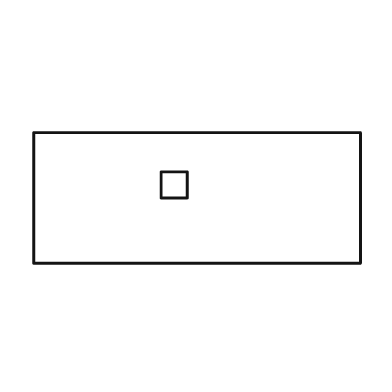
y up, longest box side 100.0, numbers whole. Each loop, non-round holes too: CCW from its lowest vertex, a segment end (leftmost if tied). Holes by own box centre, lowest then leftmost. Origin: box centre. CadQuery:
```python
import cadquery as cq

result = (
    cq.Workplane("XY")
    .moveTo(-50.0, -20.0)
    .lineTo(50.0, -20.0)
    .lineTo(50.0, 20.0)
    .lineTo(-50.0, 20.0)
    .close()
    .moveTo(-11.0, 0.0)
    .lineTo(-3.0, 0.0)
    .lineTo(-3.0, 8.0)
    .lineTo(-11.0, 8.0)
    .close()
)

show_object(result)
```